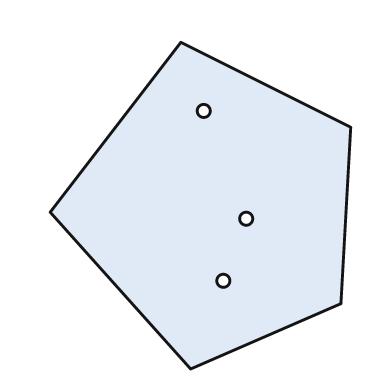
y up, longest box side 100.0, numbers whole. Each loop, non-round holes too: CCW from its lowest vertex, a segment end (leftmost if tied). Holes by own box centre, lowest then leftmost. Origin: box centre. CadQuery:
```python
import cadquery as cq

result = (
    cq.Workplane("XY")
    .moveTo(-3.0, -50.0)
    .lineTo(43.0, -30.0)
    .lineTo(46.0, 24.0)
    .lineTo(-6.0, 50.0)
    .lineTo(-46.0, -2.0)
    .close()
    .moveTo(7.0, -23.0)
    .circle(2.0)
    .moveTo(14.0, -4.0)
    .circle(2.0)
    .moveTo(1.0, 29.0)
    .circle(2.0)
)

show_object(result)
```